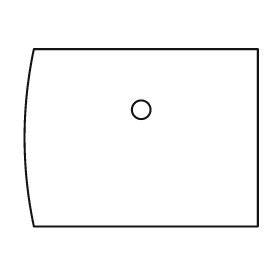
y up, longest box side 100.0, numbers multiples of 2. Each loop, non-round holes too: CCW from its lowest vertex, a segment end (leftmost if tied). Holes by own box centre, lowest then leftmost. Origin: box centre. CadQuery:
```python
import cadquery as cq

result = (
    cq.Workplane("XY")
    .moveTo(-46.0, -38.0)
    .lineTo(50.0, -38.0)
    .lineTo(50.0, 38.0)
    .lineTo(-46.0, 38.0)
    .threePointArc((-50.0, 0.0), (-46.0, -38.0))
    .close()
    .moveTo(0.0, 12.0)
    .circle(4.0)
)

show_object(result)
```